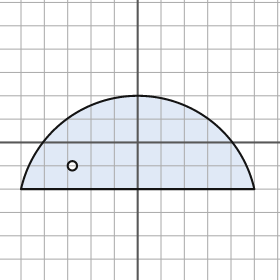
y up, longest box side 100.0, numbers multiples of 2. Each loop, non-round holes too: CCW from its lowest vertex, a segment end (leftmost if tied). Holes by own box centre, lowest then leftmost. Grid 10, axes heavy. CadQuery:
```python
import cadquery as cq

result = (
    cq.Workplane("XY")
    .moveTo(-50.0, -20.0)
    .lineTo(50.0, -20.0)
    .threePointArc((0.0, 20.0), (-50.0, -20.0))
    .close()
    .moveTo(-28.0, -10.0)
    .circle(2.0)
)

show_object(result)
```